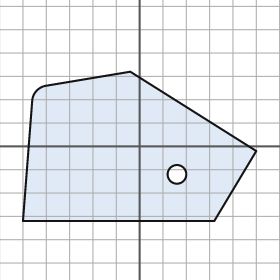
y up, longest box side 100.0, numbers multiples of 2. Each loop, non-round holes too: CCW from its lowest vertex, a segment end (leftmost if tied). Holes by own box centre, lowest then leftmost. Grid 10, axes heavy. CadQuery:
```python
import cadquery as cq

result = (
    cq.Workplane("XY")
    .moveTo(-50.0, -32.0)
    .lineTo(32.0, -32.0)
    .lineTo(50.0, -2.0)
    .lineTo(-4.0, 32.0)
    .lineTo(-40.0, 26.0)
    .threePointArc((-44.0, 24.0), (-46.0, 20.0))
    .close()
    .moveTo(16.0, -12.0)
    .circle(4.0)
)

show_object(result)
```